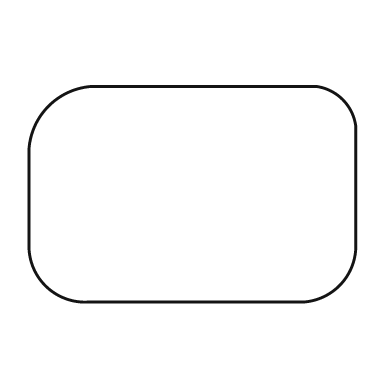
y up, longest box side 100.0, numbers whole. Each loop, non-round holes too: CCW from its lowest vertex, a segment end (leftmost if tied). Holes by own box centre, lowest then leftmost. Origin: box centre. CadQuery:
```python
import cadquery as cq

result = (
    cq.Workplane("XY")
    .moveTo(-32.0, -33.0)
    .lineTo(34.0, -33.0)
    .threePointArc((45.0, -28.0), (50.0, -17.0))
    .lineTo(50.0, 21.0)
    .threePointArc((46.0, 29.0), (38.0, 33.0))
    .lineTo(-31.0, 33.0)
    .threePointArc((-44.0, 27.0), (-50.0, 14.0))
    .lineTo(-50.0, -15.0)
    .threePointArc((-45.0, -28.0), (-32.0, -33.0))
    .close()
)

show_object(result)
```